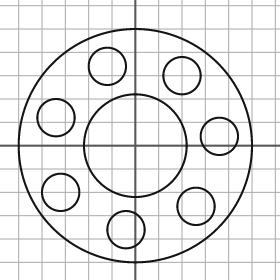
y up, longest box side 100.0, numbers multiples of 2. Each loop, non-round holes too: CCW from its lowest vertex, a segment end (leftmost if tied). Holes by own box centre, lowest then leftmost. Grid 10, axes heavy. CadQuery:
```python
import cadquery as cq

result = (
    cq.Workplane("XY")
    .moveTo(0.0, 0.0)
    .circle(50.0)
    .moveTo(-4.0, -36.0)
    .circle(8.0)
    .moveTo(26.0, -26.0)
    .circle(8.0)
    .moveTo(-32.0, -20.0)
    .circle(8.0)
    .moveTo(0.0, 0.0)
    .circle(22.0)
    .moveTo(36.0, 4.0)
    .circle(8.0)
    .moveTo(-34.0, 12.0)
    .circle(8.0)
    .moveTo(20.0, 30.0)
    .circle(8.0)
    .moveTo(-12.0, 34.0)
    .circle(8.0)
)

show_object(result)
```